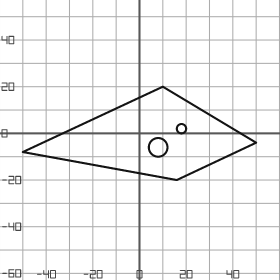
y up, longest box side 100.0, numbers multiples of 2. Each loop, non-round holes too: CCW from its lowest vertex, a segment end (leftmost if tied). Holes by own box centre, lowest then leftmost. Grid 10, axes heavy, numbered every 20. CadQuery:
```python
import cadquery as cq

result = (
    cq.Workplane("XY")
    .moveTo(16.0, -20.0)
    .lineTo(50.0, -4.0)
    .lineTo(10.0, 20.0)
    .lineTo(-50.0, -8.0)
    .close()
    .moveTo(8.0, -6.0)
    .circle(4.0)
    .moveTo(18.0, 2.0)
    .circle(2.0)
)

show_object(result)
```